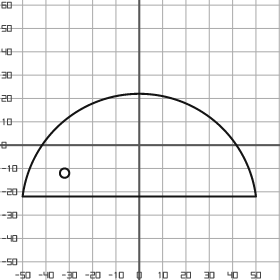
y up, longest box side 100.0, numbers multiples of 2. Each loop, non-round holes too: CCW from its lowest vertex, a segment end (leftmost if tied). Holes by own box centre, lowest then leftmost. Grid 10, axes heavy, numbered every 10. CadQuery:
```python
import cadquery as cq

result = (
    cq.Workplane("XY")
    .moveTo(-50.0, -22.0)
    .lineTo(50.0, -22.0)
    .threePointArc((0.0, 22.0), (-50.0, -22.0))
    .close()
    .moveTo(-32.0, -12.0)
    .circle(2.0)
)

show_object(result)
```